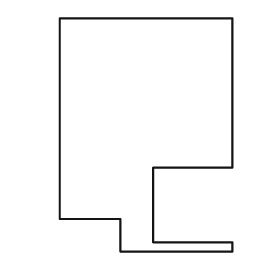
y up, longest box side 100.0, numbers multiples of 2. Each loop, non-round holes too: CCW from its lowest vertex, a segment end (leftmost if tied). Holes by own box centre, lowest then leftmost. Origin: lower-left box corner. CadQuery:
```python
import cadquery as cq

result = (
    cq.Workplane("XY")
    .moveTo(26.0, 0.0)
    .lineTo(74.0, 0.0)
    .lineTo(74.0, 4.0)
    .lineTo(40.0, 4.0)
    .lineTo(40.0, 36.0)
    .lineTo(74.0, 36.0)
    .lineTo(74.0, 100.0)
    .lineTo(0.0, 100.0)
    .lineTo(0.0, 14.0)
    .lineTo(26.0, 14.0)
    .close()
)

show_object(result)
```